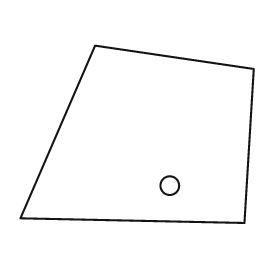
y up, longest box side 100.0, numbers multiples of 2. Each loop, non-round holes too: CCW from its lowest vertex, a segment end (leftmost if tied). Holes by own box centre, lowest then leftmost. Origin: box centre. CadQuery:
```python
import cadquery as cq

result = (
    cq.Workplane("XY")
    .moveTo(46.0, -38.0)
    .lineTo(50.0, 28.0)
    .lineTo(-18.0, 38.0)
    .lineTo(-50.0, -36.0)
    .close()
    .moveTo(14.0, -22.0)
    .circle(4.0)
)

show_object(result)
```